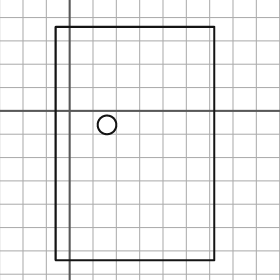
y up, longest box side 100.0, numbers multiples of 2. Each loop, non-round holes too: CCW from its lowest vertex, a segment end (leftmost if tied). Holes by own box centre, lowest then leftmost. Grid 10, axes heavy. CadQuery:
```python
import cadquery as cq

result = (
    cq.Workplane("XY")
    .moveTo(-6.0, -64.0)
    .lineTo(62.0, -64.0)
    .lineTo(62.0, 36.0)
    .lineTo(-6.0, 36.0)
    .close()
    .moveTo(16.0, -6.0)
    .circle(4.0)
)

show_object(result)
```